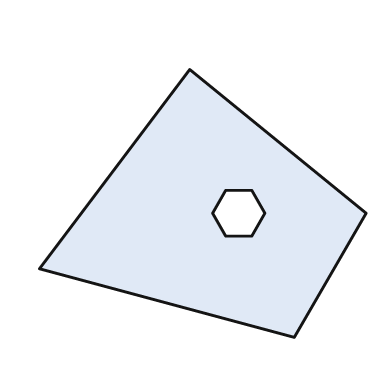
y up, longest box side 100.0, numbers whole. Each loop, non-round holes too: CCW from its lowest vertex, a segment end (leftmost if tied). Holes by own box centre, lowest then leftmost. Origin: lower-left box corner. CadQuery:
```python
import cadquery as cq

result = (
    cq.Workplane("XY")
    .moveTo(78.0, 0.0)
    .lineTo(100.0, 38.0)
    .lineTo(46.0, 82.0)
    .lineTo(0.0, 21.0)
    .close()
    .moveTo(57.0, 31.0)
    .lineTo(65.0, 31.0)
    .lineTo(69.0, 38.0)
    .lineTo(65.0, 45.0)
    .lineTo(57.0, 45.0)
    .lineTo(53.0, 38.0)
    .close()
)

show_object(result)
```